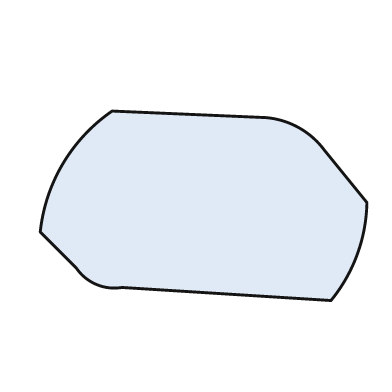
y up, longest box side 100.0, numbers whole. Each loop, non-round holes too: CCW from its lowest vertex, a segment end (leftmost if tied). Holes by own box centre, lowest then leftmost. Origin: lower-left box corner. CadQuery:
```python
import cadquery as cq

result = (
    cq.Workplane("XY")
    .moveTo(89.0, 0.0)
    .threePointArc((97.0, 14.0), (100.0, 30.0))
    .lineTo(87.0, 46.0)
    .threePointArc((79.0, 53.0), (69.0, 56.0))
    .lineTo(22.0, 58.0)
    .threePointArc((7.0, 42.0), (0.0, 21.0))
    .lineTo(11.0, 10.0)
    .threePointArc((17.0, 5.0), (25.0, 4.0))
    .close()
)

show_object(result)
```